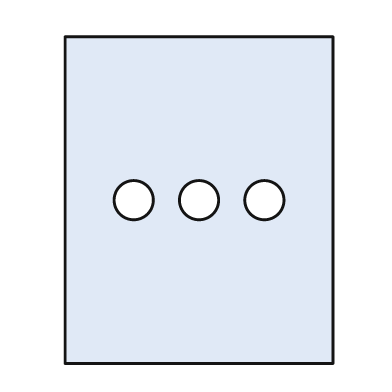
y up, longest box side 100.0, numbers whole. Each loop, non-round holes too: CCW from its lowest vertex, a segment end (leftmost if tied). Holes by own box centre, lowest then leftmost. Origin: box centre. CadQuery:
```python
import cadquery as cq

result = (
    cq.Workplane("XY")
    .moveTo(-41.0, -50.0)
    .lineTo(41.0, -50.0)
    .lineTo(41.0, 50.0)
    .lineTo(-41.0, 50.0)
    .close()
    .moveTo(-20.0, 0.0)
    .circle(6.0)
    .moveTo(0.0, 0.0)
    .circle(6.0)
    .moveTo(20.0, 0.0)
    .circle(6.0)
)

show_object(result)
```